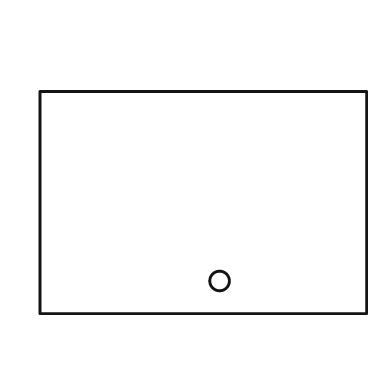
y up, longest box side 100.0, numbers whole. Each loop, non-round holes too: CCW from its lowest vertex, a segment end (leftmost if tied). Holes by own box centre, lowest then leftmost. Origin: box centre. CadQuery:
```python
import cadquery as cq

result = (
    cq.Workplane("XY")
    .moveTo(-50.0, -34.0)
    .lineTo(50.0, -34.0)
    .lineTo(50.0, 34.0)
    .lineTo(-50.0, 34.0)
    .close()
    .moveTo(5.0, -24.0)
    .circle(3.0)
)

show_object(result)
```